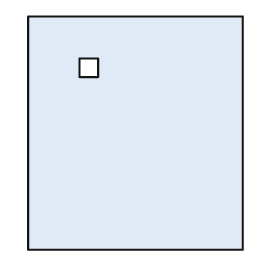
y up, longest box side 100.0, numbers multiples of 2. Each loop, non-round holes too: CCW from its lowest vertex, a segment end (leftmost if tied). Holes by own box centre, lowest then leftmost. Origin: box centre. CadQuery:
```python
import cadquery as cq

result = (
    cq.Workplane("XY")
    .moveTo(-46.0, -50.0)
    .lineTo(46.0, -50.0)
    .lineTo(46.0, 50.0)
    .lineTo(-46.0, 50.0)
    .close()
    .moveTo(-24.0, 24.0)
    .lineTo(-16.0, 24.0)
    .lineTo(-16.0, 32.0)
    .lineTo(-24.0, 32.0)
    .close()
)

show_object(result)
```